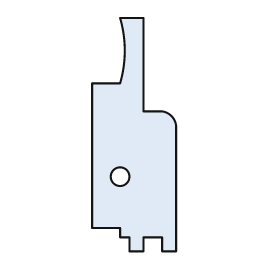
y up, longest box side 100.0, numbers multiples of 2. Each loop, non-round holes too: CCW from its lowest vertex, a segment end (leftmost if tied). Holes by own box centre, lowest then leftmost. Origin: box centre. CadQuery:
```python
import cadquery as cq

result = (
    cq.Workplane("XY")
    .moveTo(-2.0, -50.0)
    .lineTo(4.0, -50.0)
    .lineTo(4.0, -44.0)
    .lineTo(12.0, -44.0)
    .lineTo(12.0, -50.0)
    .lineTo(18.0, -50.0)
    .lineTo(18.0, 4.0)
    .threePointArc((16.0, 8.0), (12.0, 10.0))
    .lineTo(4.0, 10.0)
    .lineTo(4.0, 50.0)
    .lineTo(-6.0, 50.0)
    .threePointArc((-4.0, 36.0), (-6.0, 22.0))
    .lineTo(-18.0, 22.0)
    .lineTo(-18.0, -40.0)
    .lineTo(-6.0, -40.0)
    .lineTo(-6.0, -44.0)
    .lineTo(-2.0, -44.0)
    .close()
    .moveTo(-6.0, -18.0)
    .circle(4.0)
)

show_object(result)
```